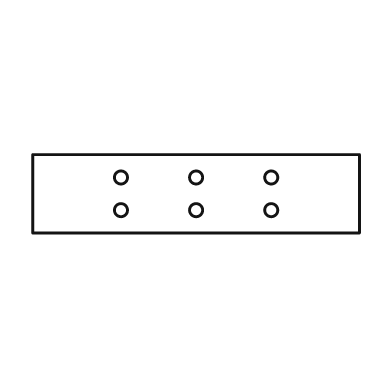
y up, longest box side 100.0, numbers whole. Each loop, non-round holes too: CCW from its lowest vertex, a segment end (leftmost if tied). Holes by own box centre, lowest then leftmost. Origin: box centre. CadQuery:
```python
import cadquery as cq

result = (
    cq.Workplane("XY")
    .moveTo(-50.0, -12.0)
    .lineTo(50.0, -12.0)
    .lineTo(50.0, 12.0)
    .lineTo(-50.0, 12.0)
    .close()
    .moveTo(-23.0, -5.0)
    .circle(2.0)
    .moveTo(0.0, -5.0)
    .circle(2.0)
    .moveTo(23.0, -5.0)
    .circle(2.0)
    .moveTo(-23.0, 5.0)
    .circle(2.0)
    .moveTo(0.0, 5.0)
    .circle(2.0)
    .moveTo(23.0, 5.0)
    .circle(2.0)
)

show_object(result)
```